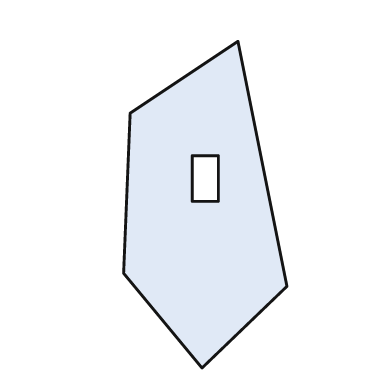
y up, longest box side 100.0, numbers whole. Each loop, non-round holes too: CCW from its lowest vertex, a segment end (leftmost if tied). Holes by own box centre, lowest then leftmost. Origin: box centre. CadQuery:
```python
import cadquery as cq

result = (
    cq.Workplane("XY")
    .moveTo(-1.0, -50.0)
    .lineTo(25.0, -25.0)
    .lineTo(10.0, 50.0)
    .lineTo(-23.0, 28.0)
    .lineTo(-25.0, -21.0)
    .close()
    .moveTo(-4.0, 1.0)
    .lineTo(4.0, 1.0)
    .lineTo(4.0, 15.0)
    .lineTo(-4.0, 15.0)
    .close()
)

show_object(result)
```